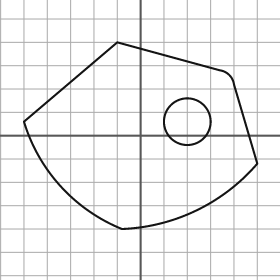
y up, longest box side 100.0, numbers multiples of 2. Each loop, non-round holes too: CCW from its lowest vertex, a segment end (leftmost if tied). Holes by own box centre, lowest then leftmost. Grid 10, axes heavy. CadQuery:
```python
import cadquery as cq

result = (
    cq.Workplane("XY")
    .moveTo(-8.0, -40.0)
    .threePointArc((24.0, -32.0), (50.0, -12.0))
    .lineTo(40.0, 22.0)
    .threePointArc((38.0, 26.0), (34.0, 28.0))
    .lineTo(-10.0, 40.0)
    .lineTo(-50.0, 6.0)
    .threePointArc((-34.0, -22.0), (-8.0, -40.0))
    .close()
    .moveTo(20.0, 6.0)
    .circle(10.0)
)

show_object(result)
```